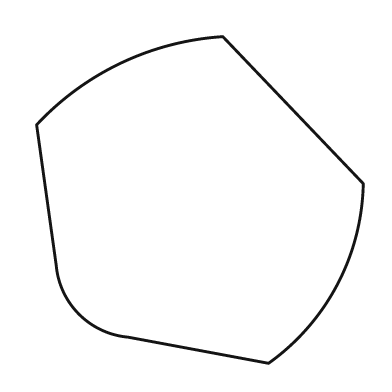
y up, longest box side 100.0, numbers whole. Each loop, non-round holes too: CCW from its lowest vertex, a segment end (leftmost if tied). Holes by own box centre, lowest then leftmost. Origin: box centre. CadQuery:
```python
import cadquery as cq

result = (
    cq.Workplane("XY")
    .moveTo(21.0, -50.0)
    .threePointArc((42.0, -26.0), (50.0, 5.0))
    .lineTo(7.0, 50.0)
    .threePointArc((-24.0, 42.0), (-50.0, 23.0))
    .lineTo(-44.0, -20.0)
    .threePointArc((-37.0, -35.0), (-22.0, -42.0))
    .close()
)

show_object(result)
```